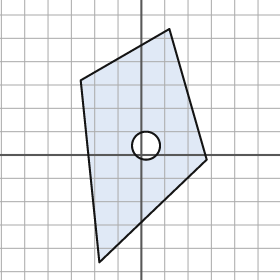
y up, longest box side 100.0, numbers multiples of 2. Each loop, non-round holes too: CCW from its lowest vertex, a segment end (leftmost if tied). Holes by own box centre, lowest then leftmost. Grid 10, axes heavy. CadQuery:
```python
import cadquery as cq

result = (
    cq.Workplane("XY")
    .moveTo(-18.0, -46.0)
    .lineTo(28.0, -2.0)
    .lineTo(12.0, 54.0)
    .lineTo(-26.0, 32.0)
    .close()
    .moveTo(2.0, 4.0)
    .circle(6.0)
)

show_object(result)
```